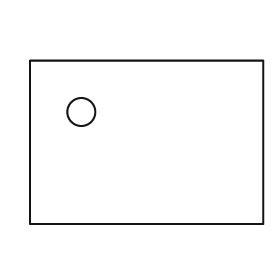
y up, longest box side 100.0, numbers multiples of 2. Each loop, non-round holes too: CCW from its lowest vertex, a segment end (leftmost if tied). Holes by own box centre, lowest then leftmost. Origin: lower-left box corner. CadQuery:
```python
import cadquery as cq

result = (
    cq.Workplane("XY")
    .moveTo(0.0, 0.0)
    .lineTo(100.0, 0.0)
    .lineTo(100.0, 70.0)
    .lineTo(0.0, 70.0)
    .close()
    .moveTo(22.0, 48.0)
    .circle(6.0)
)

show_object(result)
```